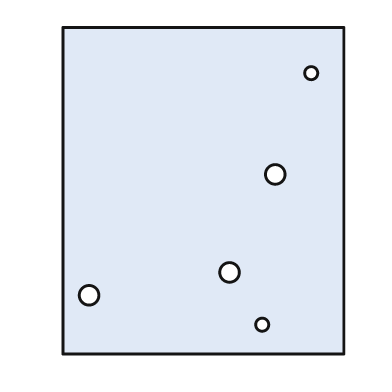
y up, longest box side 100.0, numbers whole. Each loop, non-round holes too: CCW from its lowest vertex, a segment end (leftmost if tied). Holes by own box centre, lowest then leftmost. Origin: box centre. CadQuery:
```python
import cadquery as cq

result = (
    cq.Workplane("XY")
    .moveTo(-43.0, -50.0)
    .lineTo(43.0, -50.0)
    .lineTo(43.0, 50.0)
    .lineTo(-43.0, 50.0)
    .close()
    .moveTo(18.0, -41.0)
    .circle(2.0)
    .moveTo(-35.0, -32.0)
    .circle(3.0)
    .moveTo(8.0, -25.0)
    .circle(3.0)
    .moveTo(22.0, 5.0)
    .circle(3.0)
    .moveTo(33.0, 36.0)
    .circle(2.0)
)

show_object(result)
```